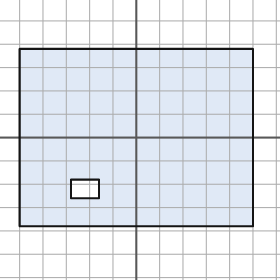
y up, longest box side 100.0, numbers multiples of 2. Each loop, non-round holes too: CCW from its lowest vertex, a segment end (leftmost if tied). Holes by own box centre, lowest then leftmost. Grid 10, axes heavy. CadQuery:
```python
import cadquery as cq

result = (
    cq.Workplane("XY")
    .moveTo(-50.0, -38.0)
    .lineTo(50.0, -38.0)
    .lineTo(50.0, 38.0)
    .lineTo(-50.0, 38.0)
    .close()
    .moveTo(-28.0, -26.0)
    .lineTo(-16.0, -26.0)
    .lineTo(-16.0, -18.0)
    .lineTo(-28.0, -18.0)
    .close()
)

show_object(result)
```